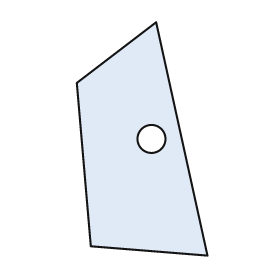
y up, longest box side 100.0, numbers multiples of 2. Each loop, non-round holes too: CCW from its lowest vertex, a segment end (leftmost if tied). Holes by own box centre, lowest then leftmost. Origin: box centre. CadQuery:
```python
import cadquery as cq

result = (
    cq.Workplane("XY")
    .moveTo(28.0, -50.0)
    .lineTo(6.0, 50.0)
    .lineTo(-28.0, 24.0)
    .lineTo(-22.0, -46.0)
    .close()
    .moveTo(4.0, 0.0)
    .circle(6.0)
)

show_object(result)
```